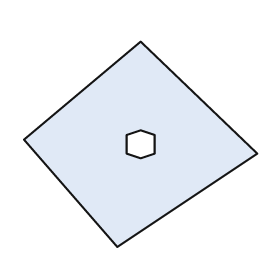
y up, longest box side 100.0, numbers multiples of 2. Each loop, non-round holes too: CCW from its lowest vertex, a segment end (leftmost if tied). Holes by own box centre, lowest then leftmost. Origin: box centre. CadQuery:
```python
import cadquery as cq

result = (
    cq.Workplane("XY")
    .moveTo(-10.0, -44.0)
    .lineTo(50.0, -4.0)
    .lineTo(0.0, 44.0)
    .lineTo(-50.0, 2.0)
    .close()
    .moveTo(0.0, -6.0)
    .lineTo(6.0, -4.0)
    .lineTo(6.0, 4.0)
    .lineTo(0.0, 6.0)
    .lineTo(-6.0, 4.0)
    .lineTo(-6.0, -4.0)
    .close()
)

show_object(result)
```